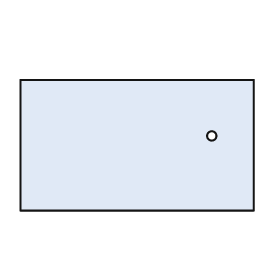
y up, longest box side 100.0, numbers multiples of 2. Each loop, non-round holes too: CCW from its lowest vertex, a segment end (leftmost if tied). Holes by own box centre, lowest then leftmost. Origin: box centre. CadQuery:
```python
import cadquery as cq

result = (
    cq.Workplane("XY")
    .moveTo(-50.0, -28.0)
    .lineTo(50.0, -28.0)
    .lineTo(50.0, 28.0)
    .lineTo(-50.0, 28.0)
    .close()
    .moveTo(32.0, 4.0)
    .circle(2.0)
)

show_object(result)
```